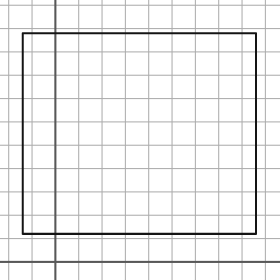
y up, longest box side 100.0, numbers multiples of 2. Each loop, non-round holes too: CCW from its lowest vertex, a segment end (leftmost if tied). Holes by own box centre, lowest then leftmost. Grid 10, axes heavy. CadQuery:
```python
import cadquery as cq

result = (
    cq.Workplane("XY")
    .moveTo(-14.0, 12.0)
    .lineTo(86.0, 12.0)
    .lineTo(86.0, 98.0)
    .lineTo(-14.0, 98.0)
    .close()
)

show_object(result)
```